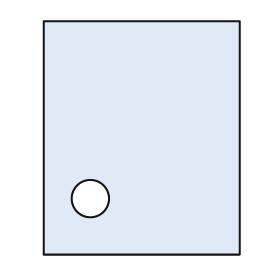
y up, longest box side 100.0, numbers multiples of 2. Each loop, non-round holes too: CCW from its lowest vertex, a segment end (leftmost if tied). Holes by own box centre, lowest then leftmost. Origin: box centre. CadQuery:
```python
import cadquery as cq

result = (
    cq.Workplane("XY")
    .moveTo(-42.0, -50.0)
    .lineTo(42.0, -50.0)
    .lineTo(42.0, 50.0)
    .lineTo(-42.0, 50.0)
    .close()
    .moveTo(-22.0, -26.0)
    .circle(8.0)
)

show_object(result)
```